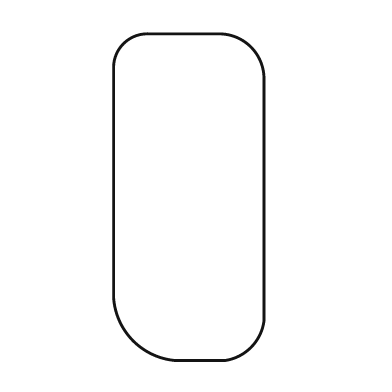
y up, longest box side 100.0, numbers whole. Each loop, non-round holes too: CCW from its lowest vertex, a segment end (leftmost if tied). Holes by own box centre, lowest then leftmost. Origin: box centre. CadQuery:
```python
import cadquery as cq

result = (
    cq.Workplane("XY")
    .moveTo(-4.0, -50.0)
    .lineTo(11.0, -50.0)
    .threePointArc((19.0, -46.0), (23.0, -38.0))
    .lineTo(23.0, 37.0)
    .threePointArc((19.0, 46.0), (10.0, 50.0))
    .lineTo(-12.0, 50.0)
    .threePointArc((-20.0, 47.0), (-23.0, 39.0))
    .lineTo(-23.0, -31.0)
    .threePointArc((-17.0, -44.0), (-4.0, -50.0))
    .close()
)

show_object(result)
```